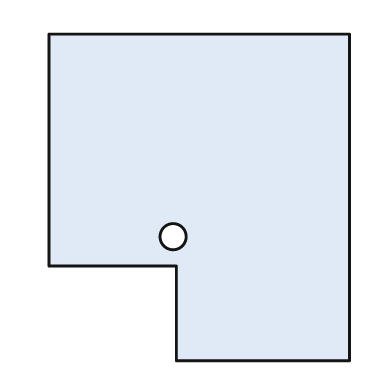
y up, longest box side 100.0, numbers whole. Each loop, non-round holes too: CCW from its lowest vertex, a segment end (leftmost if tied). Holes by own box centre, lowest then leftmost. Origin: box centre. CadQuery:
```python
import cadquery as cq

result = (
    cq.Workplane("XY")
    .moveTo(-7.0, -50.0)
    .lineTo(46.0, -50.0)
    .lineTo(46.0, 50.0)
    .lineTo(-46.0, 50.0)
    .lineTo(-46.0, -21.0)
    .lineTo(-7.0, -21.0)
    .close()
    .moveTo(-8.0, -12.0)
    .circle(4.0)
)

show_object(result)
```